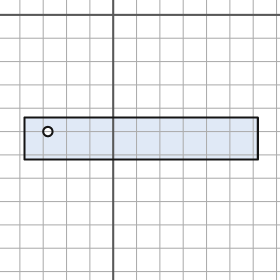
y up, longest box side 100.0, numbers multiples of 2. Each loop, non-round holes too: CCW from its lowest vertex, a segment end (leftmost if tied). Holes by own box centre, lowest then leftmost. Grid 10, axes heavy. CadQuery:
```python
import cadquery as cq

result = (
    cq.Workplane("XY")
    .moveTo(-38.0, -62.0)
    .lineTo(62.0, -62.0)
    .lineTo(62.0, -44.0)
    .lineTo(-38.0, -44.0)
    .close()
    .moveTo(-28.0, -50.0)
    .circle(2.0)
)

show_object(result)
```